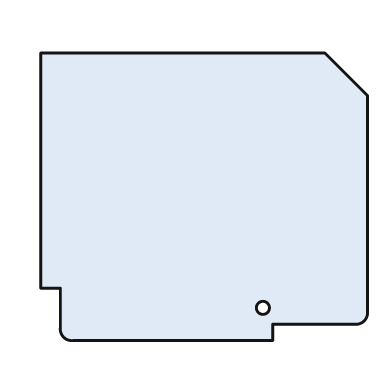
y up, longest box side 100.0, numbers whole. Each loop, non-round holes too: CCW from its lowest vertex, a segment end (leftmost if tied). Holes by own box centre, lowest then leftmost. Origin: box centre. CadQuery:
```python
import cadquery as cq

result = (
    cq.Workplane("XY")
    .moveTo(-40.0, -44.0)
    .lineTo(21.0, -44.0)
    .lineTo(21.0, -39.0)
    .lineTo(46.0, -39.0)
    .threePointArc((49.0, -38.0), (50.0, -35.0))
    .lineTo(50.0, 31.0)
    .lineTo(37.0, 44.0)
    .lineTo(-50.0, 44.0)
    .lineTo(-50.0, -28.0)
    .lineTo(-44.0, -28.0)
    .lineTo(-44.0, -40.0)
    .threePointArc((-43.0, -43.0), (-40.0, -44.0))
    .close()
    .moveTo(18.0, -34.0)
    .circle(2.0)
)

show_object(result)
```